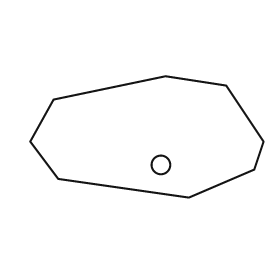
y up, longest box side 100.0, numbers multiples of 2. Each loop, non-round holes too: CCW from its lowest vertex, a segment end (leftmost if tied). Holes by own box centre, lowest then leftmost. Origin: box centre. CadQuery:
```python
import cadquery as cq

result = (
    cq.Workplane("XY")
    .moveTo(18.0, -26.0)
    .lineTo(46.0, -14.0)
    .lineTo(50.0, -2.0)
    .lineTo(34.0, 22.0)
    .lineTo(8.0, 26.0)
    .lineTo(-40.0, 16.0)
    .lineTo(-50.0, -2.0)
    .lineTo(-38.0, -18.0)
    .close()
    .moveTo(6.0, -12.0)
    .circle(4.0)
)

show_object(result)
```